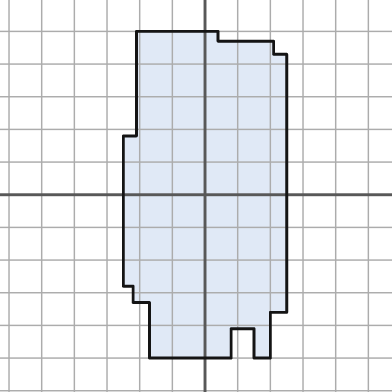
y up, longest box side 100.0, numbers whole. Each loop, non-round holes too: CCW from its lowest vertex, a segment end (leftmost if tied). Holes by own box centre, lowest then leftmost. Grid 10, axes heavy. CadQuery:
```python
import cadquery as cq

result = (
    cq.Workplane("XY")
    .moveTo(-17.0, -50.0)
    .lineTo(8.0, -50.0)
    .lineTo(8.0, -41.0)
    .lineTo(15.0, -41.0)
    .lineTo(15.0, -50.0)
    .lineTo(20.0, -50.0)
    .lineTo(20.0, -36.0)
    .lineTo(25.0, -36.0)
    .lineTo(25.0, 43.0)
    .lineTo(21.0, 43.0)
    .lineTo(21.0, 47.0)
    .lineTo(4.0, 47.0)
    .lineTo(4.0, 50.0)
    .lineTo(-21.0, 50.0)
    .lineTo(-21.0, 18.0)
    .lineTo(-25.0, 18.0)
    .lineTo(-25.0, -28.0)
    .lineTo(-22.0, -28.0)
    .lineTo(-22.0, -33.0)
    .lineTo(-17.0, -33.0)
    .close()
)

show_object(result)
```